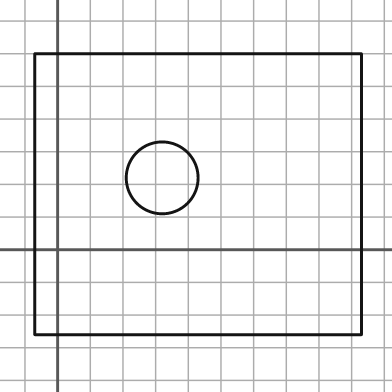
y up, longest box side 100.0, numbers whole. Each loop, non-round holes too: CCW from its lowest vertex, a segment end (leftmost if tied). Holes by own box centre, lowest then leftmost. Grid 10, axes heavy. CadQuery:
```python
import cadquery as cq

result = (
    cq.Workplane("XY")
    .moveTo(-7.0, -26.0)
    .lineTo(93.0, -26.0)
    .lineTo(93.0, 60.0)
    .lineTo(-7.0, 60.0)
    .close()
    .moveTo(32.0, 22.0)
    .circle(11.0)
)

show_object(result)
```